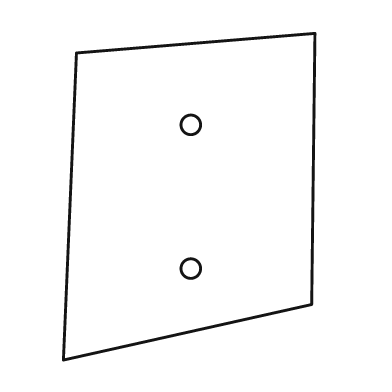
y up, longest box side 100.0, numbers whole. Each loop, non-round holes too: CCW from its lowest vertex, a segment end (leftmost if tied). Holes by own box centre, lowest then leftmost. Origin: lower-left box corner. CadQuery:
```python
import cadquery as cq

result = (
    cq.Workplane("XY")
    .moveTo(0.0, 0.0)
    .lineTo(76.0, 17.0)
    .lineTo(77.0, 100.0)
    .lineTo(4.0, 94.0)
    .close()
    .moveTo(39.0, 28.0)
    .circle(3.0)
    .moveTo(39.0, 72.0)
    .circle(3.0)
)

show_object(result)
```